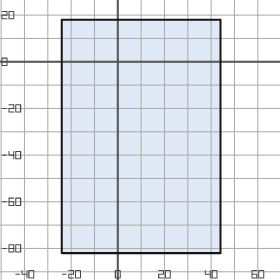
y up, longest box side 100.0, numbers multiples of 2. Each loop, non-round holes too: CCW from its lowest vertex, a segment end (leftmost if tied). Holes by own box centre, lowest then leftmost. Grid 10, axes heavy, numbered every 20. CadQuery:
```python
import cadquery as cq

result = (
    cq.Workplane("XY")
    .moveTo(-24.0, -82.0)
    .lineTo(44.0, -82.0)
    .lineTo(44.0, 18.0)
    .lineTo(-24.0, 18.0)
    .close()
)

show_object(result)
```